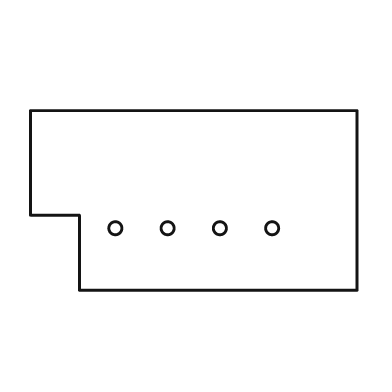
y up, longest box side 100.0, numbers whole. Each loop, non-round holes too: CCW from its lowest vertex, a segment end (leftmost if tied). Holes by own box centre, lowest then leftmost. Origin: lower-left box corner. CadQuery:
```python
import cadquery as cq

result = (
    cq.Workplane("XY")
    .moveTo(15.0, 0.0)
    .lineTo(100.0, 0.0)
    .lineTo(100.0, 55.0)
    .lineTo(0.0, 55.0)
    .lineTo(0.0, 23.0)
    .lineTo(15.0, 23.0)
    .close()
    .moveTo(26.0, 19.0)
    .circle(2.0)
    .moveTo(42.0, 19.0)
    .circle(2.0)
    .moveTo(58.0, 19.0)
    .circle(2.0)
    .moveTo(74.0, 19.0)
    .circle(2.0)
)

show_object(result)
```